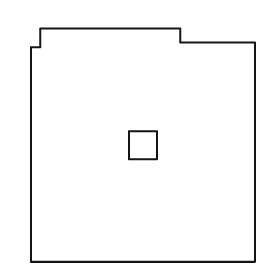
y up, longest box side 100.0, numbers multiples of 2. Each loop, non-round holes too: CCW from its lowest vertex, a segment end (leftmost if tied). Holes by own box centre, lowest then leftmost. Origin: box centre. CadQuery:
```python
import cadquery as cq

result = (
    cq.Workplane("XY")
    .moveTo(-48.0, -50.0)
    .lineTo(48.0, -50.0)
    .lineTo(48.0, 44.0)
    .lineTo(16.0, 44.0)
    .lineTo(16.0, 50.0)
    .lineTo(-44.0, 50.0)
    .lineTo(-44.0, 42.0)
    .lineTo(-48.0, 42.0)
    .close()
    .moveTo(-6.0, -6.0)
    .lineTo(6.0, -6.0)
    .lineTo(6.0, 6.0)
    .lineTo(-6.0, 6.0)
    .close()
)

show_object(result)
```